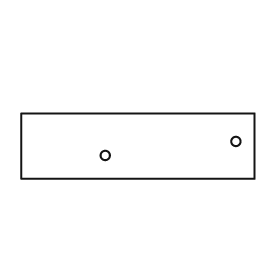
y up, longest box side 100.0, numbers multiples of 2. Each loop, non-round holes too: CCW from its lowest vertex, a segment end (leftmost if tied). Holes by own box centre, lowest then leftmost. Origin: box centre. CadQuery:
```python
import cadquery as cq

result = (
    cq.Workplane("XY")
    .moveTo(-50.0, -14.0)
    .lineTo(50.0, -14.0)
    .lineTo(50.0, 14.0)
    .lineTo(-50.0, 14.0)
    .close()
    .moveTo(-14.0, -4.0)
    .circle(2.0)
    .moveTo(42.0, 2.0)
    .circle(2.0)
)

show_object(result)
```